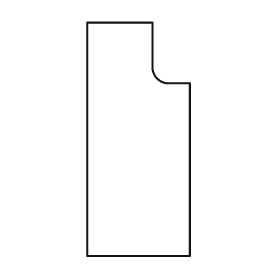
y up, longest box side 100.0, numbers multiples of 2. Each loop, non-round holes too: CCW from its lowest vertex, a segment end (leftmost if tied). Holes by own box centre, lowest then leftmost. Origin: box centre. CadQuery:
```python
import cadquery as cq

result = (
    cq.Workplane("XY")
    .moveTo(-22.0, -50.0)
    .lineTo(22.0, -50.0)
    .lineTo(22.0, 24.0)
    .lineTo(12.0, 24.0)
    .threePointArc((8.0, 26.0), (6.0, 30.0))
    .lineTo(6.0, 50.0)
    .lineTo(-22.0, 50.0)
    .close()
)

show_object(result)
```